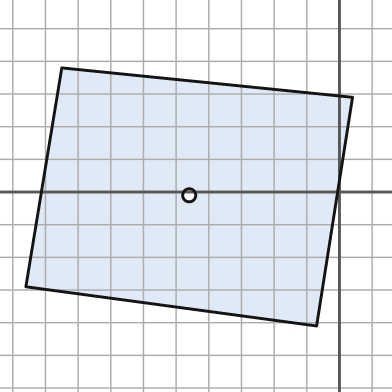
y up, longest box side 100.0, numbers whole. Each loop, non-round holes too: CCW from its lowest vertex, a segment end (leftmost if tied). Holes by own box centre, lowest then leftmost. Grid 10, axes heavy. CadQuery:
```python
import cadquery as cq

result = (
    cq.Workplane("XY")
    .moveTo(-7.0, -41.0)
    .lineTo(4.0, 29.0)
    .lineTo(-85.0, 38.0)
    .lineTo(-96.0, -29.0)
    .close()
    .moveTo(-46.0, -1.0)
    .circle(2.0)
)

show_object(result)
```